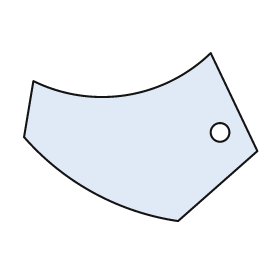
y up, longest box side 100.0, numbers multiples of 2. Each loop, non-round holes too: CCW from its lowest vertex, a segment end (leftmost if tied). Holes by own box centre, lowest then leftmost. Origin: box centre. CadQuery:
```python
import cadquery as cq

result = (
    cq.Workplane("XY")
    .moveTo(16.0, -36.0)
    .lineTo(50.0, -6.0)
    .lineTo(30.0, 36.0)
    .threePointArc((-6.0, 18.0), (-46.0, 24.0))
    .lineTo(-50.0, 0.0)
    .threePointArc((-20.0, -24.0), (16.0, -36.0))
    .close()
    .moveTo(34.0, 2.0)
    .circle(4.0)
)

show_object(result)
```